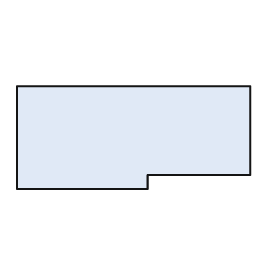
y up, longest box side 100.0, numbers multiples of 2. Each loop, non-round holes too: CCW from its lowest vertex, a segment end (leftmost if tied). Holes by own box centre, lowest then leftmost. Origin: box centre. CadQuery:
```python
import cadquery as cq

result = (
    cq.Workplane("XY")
    .moveTo(-50.0, -22.0)
    .lineTo(6.0, -22.0)
    .lineTo(6.0, -16.0)
    .lineTo(50.0, -16.0)
    .lineTo(50.0, 22.0)
    .lineTo(-50.0, 22.0)
    .close()
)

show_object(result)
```